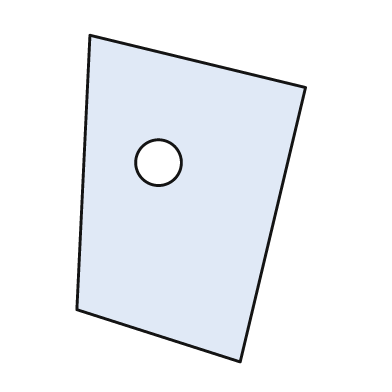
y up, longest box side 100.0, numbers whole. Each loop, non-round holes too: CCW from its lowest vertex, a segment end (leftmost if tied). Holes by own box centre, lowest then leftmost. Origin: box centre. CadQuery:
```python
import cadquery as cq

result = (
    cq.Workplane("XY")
    .moveTo(15.0, -50.0)
    .lineTo(35.0, 34.0)
    .lineTo(-31.0, 50.0)
    .lineTo(-35.0, -34.0)
    .close()
    .moveTo(-10.0, 11.0)
    .circle(7.0)
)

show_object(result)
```